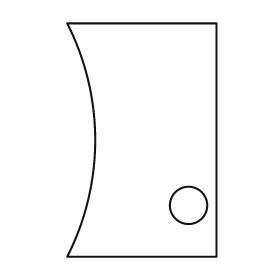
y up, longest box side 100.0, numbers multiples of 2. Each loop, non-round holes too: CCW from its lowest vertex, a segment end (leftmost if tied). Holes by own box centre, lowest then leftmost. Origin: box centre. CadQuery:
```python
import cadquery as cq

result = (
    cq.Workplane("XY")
    .moveTo(-32.0, -50.0)
    .lineTo(32.0, -50.0)
    .lineTo(32.0, 50.0)
    .lineTo(-32.0, 50.0)
    .threePointArc((-20.0, 0.0), (-32.0, -50.0))
    .close()
    .moveTo(20.0, -28.0)
    .circle(8.0)
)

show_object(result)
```